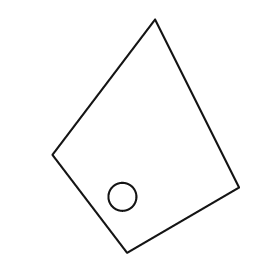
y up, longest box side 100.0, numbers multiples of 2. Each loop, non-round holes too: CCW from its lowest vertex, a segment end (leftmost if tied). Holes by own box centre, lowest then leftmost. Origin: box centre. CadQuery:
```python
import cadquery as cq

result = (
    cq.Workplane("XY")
    .moveTo(-8.0, -50.0)
    .lineTo(40.0, -22.0)
    .lineTo(4.0, 50.0)
    .lineTo(-40.0, -8.0)
    .close()
    .moveTo(-10.0, -26.0)
    .circle(6.0)
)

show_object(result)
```